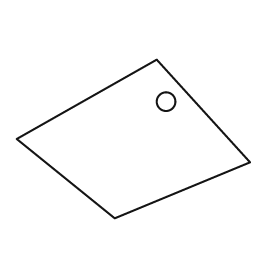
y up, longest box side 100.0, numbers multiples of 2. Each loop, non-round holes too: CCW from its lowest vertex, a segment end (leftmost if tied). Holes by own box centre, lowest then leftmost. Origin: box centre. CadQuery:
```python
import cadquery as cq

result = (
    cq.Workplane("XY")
    .moveTo(-8.0, -34.0)
    .lineTo(50.0, -10.0)
    .lineTo(10.0, 34.0)
    .lineTo(-50.0, 0.0)
    .close()
    .moveTo(14.0, 16.0)
    .circle(4.0)
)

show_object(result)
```